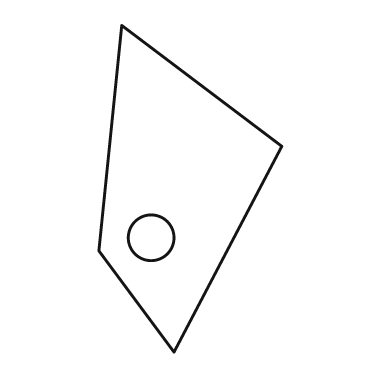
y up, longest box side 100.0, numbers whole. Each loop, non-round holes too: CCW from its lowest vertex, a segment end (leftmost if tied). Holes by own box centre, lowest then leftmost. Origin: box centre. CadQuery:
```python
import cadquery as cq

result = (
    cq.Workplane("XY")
    .moveTo(-5.0, -50.0)
    .lineTo(28.0, 13.0)
    .lineTo(-21.0, 50.0)
    .lineTo(-28.0, -19.0)
    .close()
    .moveTo(-12.0, -15.0)
    .circle(7.0)
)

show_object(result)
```